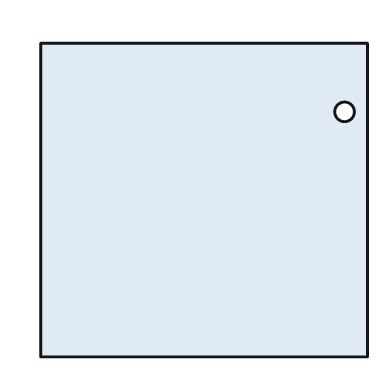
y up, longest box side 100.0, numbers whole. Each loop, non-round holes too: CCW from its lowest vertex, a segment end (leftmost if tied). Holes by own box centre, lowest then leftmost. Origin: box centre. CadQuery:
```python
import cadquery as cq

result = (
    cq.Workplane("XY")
    .moveTo(-50.0, -48.0)
    .lineTo(50.0, -48.0)
    .lineTo(50.0, 48.0)
    .lineTo(-50.0, 48.0)
    .close()
    .moveTo(43.0, 27.0)
    .circle(3.0)
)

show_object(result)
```